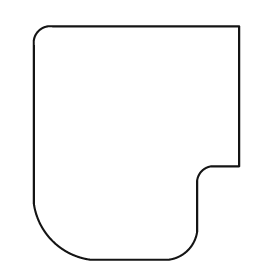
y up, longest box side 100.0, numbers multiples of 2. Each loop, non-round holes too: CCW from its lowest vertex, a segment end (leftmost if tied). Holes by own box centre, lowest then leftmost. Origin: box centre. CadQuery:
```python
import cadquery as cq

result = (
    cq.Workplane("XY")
    .moveTo(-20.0, -50.0)
    .lineTo(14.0, -50.0)
    .threePointArc((22.0, -46.0), (26.0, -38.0))
    .lineTo(26.0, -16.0)
    .threePointArc((28.0, -12.0), (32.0, -10.0))
    .lineTo(44.0, -10.0)
    .lineTo(44.0, 50.0)
    .lineTo(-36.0, 50.0)
    .threePointArc((-42.0, 48.0), (-44.0, 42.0))
    .lineTo(-44.0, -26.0)
    .threePointArc((-36.0, -42.0), (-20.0, -50.0))
    .close()
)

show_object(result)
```